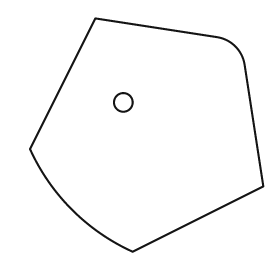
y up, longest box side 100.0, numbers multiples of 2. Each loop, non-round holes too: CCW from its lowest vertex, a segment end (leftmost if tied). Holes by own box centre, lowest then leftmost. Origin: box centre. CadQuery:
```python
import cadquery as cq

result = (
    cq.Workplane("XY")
    .moveTo(-6.0, -50.0)
    .lineTo(50.0, -22.0)
    .lineTo(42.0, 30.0)
    .threePointArc((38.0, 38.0), (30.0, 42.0))
    .lineTo(-22.0, 50.0)
    .lineTo(-50.0, -6.0)
    .threePointArc((-32.0, -32.0), (-6.0, -50.0))
    .close()
    .moveTo(-10.0, 14.0)
    .circle(4.0)
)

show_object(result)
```